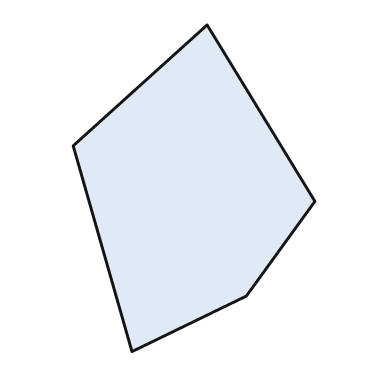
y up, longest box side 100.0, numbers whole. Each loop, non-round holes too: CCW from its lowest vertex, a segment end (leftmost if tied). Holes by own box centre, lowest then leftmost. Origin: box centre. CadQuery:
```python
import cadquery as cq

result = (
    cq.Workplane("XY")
    .moveTo(-19.0, -50.0)
    .lineTo(16.0, -33.0)
    .lineTo(37.0, -4.0)
    .lineTo(4.0, 50.0)
    .lineTo(-37.0, 13.0)
    .close()
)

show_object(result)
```